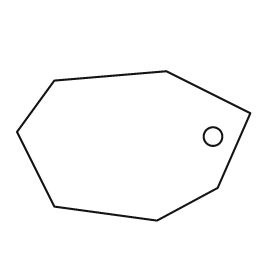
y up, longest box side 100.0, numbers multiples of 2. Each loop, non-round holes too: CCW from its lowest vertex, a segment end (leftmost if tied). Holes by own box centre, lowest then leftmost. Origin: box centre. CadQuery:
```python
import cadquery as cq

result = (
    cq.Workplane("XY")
    .moveTo(10.0, -32.0)
    .lineTo(36.0, -18.0)
    .lineTo(50.0, 14.0)
    .lineTo(14.0, 32.0)
    .lineTo(-34.0, 28.0)
    .lineTo(-50.0, 6.0)
    .lineTo(-34.0, -26.0)
    .close()
    .moveTo(34.0, 4.0)
    .circle(4.0)
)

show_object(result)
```